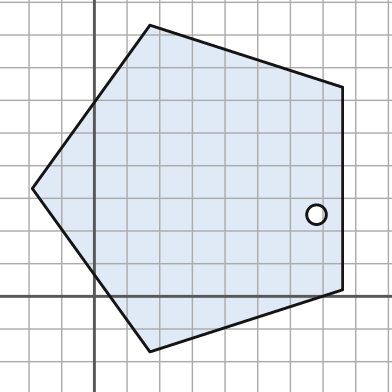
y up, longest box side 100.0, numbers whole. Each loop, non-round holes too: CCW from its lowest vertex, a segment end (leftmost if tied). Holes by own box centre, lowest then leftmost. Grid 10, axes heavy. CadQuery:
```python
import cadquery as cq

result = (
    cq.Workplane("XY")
    .moveTo(17.0, -17.0)
    .lineTo(76.0, 2.0)
    .lineTo(76.0, 64.0)
    .lineTo(17.0, 83.0)
    .lineTo(-19.0, 33.0)
    .close()
    .moveTo(68.0, 25.0)
    .circle(3.0)
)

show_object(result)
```